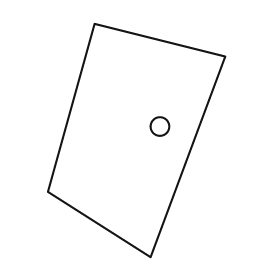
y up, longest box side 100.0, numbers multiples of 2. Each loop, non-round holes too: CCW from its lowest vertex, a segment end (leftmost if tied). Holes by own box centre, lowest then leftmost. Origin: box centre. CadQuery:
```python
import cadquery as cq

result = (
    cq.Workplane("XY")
    .moveTo(6.0, -50.0)
    .lineTo(38.0, 36.0)
    .lineTo(-18.0, 50.0)
    .lineTo(-38.0, -22.0)
    .close()
    .moveTo(10.0, 6.0)
    .circle(4.0)
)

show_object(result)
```